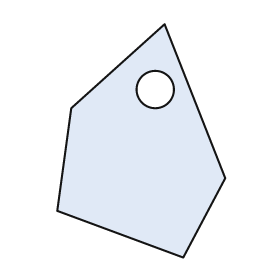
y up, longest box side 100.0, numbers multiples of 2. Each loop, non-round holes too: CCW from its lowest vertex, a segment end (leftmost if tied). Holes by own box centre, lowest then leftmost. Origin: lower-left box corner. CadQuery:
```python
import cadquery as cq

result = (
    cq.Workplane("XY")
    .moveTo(54.0, 0.0)
    .lineTo(72.0, 34.0)
    .lineTo(46.0, 100.0)
    .lineTo(6.0, 64.0)
    .lineTo(0.0, 20.0)
    .close()
    .moveTo(42.0, 72.0)
    .circle(8.0)
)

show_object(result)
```